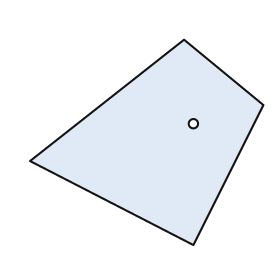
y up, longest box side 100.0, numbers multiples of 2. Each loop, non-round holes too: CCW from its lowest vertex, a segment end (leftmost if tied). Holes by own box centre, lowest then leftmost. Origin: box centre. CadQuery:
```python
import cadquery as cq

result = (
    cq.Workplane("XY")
    .moveTo(20.0, -44.0)
    .lineTo(50.0, 16.0)
    .lineTo(16.0, 44.0)
    .lineTo(-50.0, -8.0)
    .close()
    .moveTo(20.0, 8.0)
    .circle(2.0)
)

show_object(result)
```